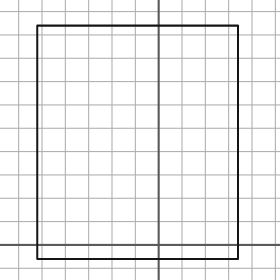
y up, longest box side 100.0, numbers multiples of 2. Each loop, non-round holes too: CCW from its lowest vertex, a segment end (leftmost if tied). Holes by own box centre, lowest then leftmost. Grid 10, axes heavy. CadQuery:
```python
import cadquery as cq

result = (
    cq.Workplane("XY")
    .moveTo(-52.0, -6.0)
    .lineTo(34.0, -6.0)
    .lineTo(34.0, 94.0)
    .lineTo(-52.0, 94.0)
    .close()
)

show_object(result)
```